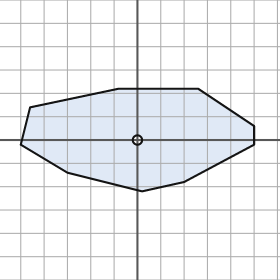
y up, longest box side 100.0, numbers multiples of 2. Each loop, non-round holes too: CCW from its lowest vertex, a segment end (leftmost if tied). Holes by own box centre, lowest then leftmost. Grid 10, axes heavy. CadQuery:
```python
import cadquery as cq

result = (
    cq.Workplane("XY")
    .moveTo(2.0, -22.0)
    .lineTo(20.0, -18.0)
    .lineTo(50.0, -2.0)
    .lineTo(50.0, 6.0)
    .lineTo(26.0, 22.0)
    .lineTo(-8.0, 22.0)
    .lineTo(-46.0, 14.0)
    .lineTo(-50.0, -2.0)
    .lineTo(-30.0, -14.0)
    .close()
    .moveTo(0.0, 0.0)
    .circle(2.0)
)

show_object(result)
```